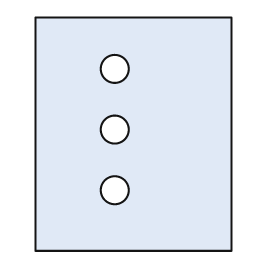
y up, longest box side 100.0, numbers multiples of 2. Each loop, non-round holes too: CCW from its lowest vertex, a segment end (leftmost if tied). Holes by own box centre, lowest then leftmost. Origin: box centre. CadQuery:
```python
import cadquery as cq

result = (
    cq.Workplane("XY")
    .moveTo(-42.0, -50.0)
    .lineTo(42.0, -50.0)
    .lineTo(42.0, 50.0)
    .lineTo(-42.0, 50.0)
    .close()
    .moveTo(-8.0, -24.0)
    .circle(6.0)
    .moveTo(-8.0, 2.0)
    .circle(6.0)
    .moveTo(-8.0, 28.0)
    .circle(6.0)
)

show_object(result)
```